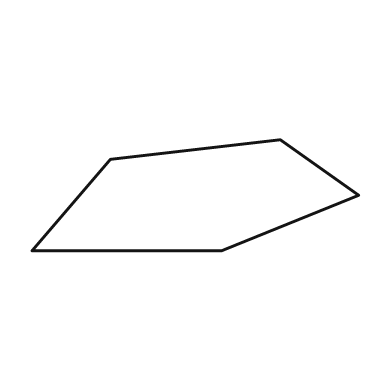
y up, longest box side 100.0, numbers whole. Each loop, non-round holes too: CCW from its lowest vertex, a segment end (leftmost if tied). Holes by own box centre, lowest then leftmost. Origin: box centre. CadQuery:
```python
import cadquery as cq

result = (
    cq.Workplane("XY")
    .moveTo(-50.0, -17.0)
    .lineTo(8.0, -17.0)
    .lineTo(50.0, 0.0)
    .lineTo(26.0, 17.0)
    .lineTo(-26.0, 11.0)
    .close()
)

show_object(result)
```